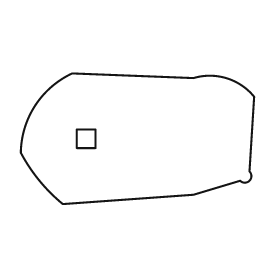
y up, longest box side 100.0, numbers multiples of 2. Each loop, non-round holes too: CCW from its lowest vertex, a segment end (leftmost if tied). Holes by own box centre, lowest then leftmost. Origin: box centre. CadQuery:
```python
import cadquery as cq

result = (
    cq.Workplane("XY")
    .moveTo(-32.0, -28.0)
    .lineTo(24.0, -24.0)
    .lineTo(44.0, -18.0)
    .threePointArc((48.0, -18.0), (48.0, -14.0))
    .lineTo(50.0, 18.0)
    .threePointArc((38.0, 26.0), (24.0, 26.0))
    .lineTo(-28.0, 28.0)
    .threePointArc((-44.0, 14.0), (-50.0, -6.0))
    .threePointArc((-42.0, -18.0), (-32.0, -28.0))
    .close()
    .moveTo(-26.0, -4.0)
    .lineTo(-18.0, -4.0)
    .lineTo(-18.0, 4.0)
    .lineTo(-26.0, 4.0)
    .close()
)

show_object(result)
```